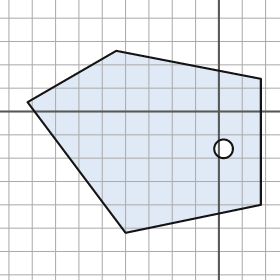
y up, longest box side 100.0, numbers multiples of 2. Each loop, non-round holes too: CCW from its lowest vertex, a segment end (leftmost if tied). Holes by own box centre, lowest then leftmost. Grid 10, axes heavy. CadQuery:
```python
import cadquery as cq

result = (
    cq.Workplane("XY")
    .moveTo(-40.0, -52.0)
    .lineTo(18.0, -40.0)
    .lineTo(18.0, 14.0)
    .lineTo(-44.0, 26.0)
    .lineTo(-82.0, 4.0)
    .close()
    .moveTo(2.0, -16.0)
    .circle(4.0)
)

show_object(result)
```